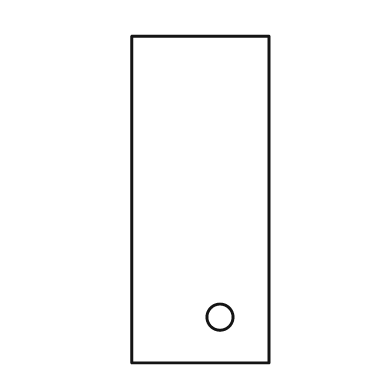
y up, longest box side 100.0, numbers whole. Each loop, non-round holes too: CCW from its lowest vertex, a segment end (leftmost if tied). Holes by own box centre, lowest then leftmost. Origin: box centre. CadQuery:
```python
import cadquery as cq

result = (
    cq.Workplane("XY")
    .moveTo(-21.0, -50.0)
    .lineTo(21.0, -50.0)
    .lineTo(21.0, 50.0)
    .lineTo(-21.0, 50.0)
    .close()
    .moveTo(6.0, -36.0)
    .circle(4.0)
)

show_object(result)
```